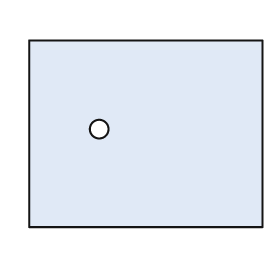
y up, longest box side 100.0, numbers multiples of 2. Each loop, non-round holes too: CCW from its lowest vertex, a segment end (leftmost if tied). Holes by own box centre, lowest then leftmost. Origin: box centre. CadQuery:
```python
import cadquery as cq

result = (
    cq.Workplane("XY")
    .moveTo(-50.0, -40.0)
    .lineTo(50.0, -40.0)
    .lineTo(50.0, 40.0)
    .lineTo(-50.0, 40.0)
    .close()
    .moveTo(-20.0, 2.0)
    .circle(4.0)
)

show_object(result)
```